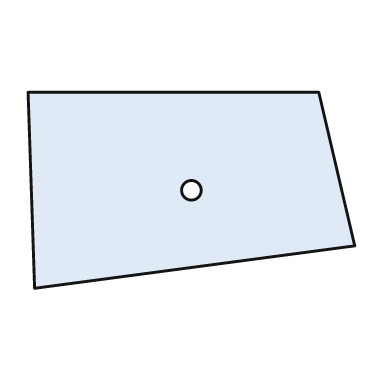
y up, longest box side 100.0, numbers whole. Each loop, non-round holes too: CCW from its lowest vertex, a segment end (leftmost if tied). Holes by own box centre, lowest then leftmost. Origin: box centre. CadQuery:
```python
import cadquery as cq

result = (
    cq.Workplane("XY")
    .moveTo(-48.0, -30.0)
    .lineTo(50.0, -17.0)
    .lineTo(39.0, 30.0)
    .lineTo(-50.0, 30.0)
    .close()
    .moveTo(0.0, 0.0)
    .circle(3.0)
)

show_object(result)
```